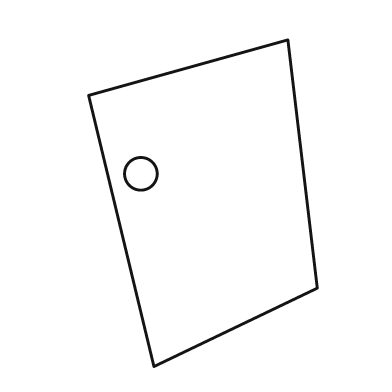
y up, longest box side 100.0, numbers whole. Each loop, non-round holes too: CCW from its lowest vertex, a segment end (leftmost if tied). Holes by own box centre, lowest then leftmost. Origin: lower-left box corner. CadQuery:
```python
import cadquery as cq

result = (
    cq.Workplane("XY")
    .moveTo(20.0, 0.0)
    .lineTo(70.0, 24.0)
    .lineTo(61.0, 100.0)
    .lineTo(0.0, 83.0)
    .close()
    .moveTo(16.0, 59.0)
    .circle(5.0)
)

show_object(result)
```